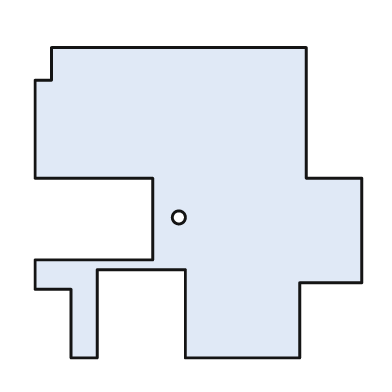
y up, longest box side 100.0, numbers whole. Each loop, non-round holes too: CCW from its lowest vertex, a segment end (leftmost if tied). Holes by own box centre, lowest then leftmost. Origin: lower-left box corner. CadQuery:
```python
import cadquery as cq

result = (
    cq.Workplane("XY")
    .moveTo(11.0, 0.0)
    .lineTo(19.0, 0.0)
    .lineTo(19.0, 27.0)
    .lineTo(46.0, 27.0)
    .lineTo(46.0, 0.0)
    .lineTo(81.0, 0.0)
    .lineTo(81.0, 23.0)
    .lineTo(100.0, 23.0)
    .lineTo(100.0, 55.0)
    .lineTo(83.0, 55.0)
    .lineTo(83.0, 95.0)
    .lineTo(5.0, 95.0)
    .lineTo(5.0, 85.0)
    .lineTo(0.0, 85.0)
    .lineTo(0.0, 55.0)
    .lineTo(36.0, 55.0)
    .lineTo(36.0, 30.0)
    .lineTo(0.0, 30.0)
    .lineTo(0.0, 21.0)
    .lineTo(11.0, 21.0)
    .close()
    .moveTo(44.0, 43.0)
    .circle(2.0)
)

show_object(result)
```